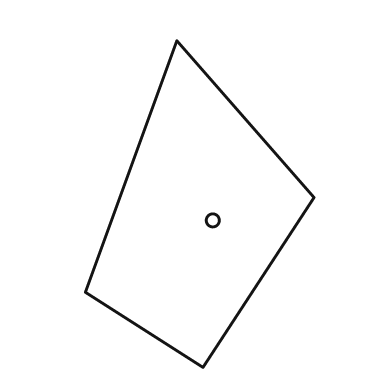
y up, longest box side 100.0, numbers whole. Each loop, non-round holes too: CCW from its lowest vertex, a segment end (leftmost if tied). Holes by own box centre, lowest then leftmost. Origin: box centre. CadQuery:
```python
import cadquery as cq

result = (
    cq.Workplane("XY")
    .moveTo(1.0, -50.0)
    .lineTo(35.0, 2.0)
    .lineTo(-7.0, 50.0)
    .lineTo(-35.0, -27.0)
    .close()
    .moveTo(4.0, -5.0)
    .circle(2.0)
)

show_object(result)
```